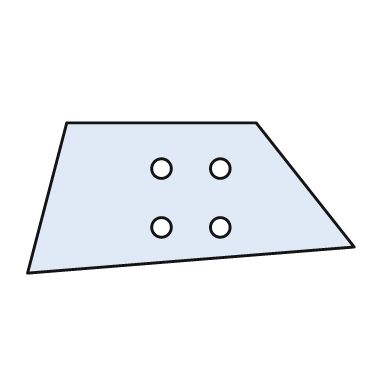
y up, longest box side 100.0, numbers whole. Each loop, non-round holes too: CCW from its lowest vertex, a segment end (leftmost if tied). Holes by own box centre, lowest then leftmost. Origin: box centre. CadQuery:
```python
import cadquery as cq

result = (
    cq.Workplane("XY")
    .moveTo(-50.0, -23.0)
    .lineTo(50.0, -15.0)
    .lineTo(20.0, 23.0)
    .lineTo(-38.0, 23.0)
    .close()
    .moveTo(-9.0, -9.0)
    .circle(3.0)
    .moveTo(9.0, -9.0)
    .circle(3.0)
    .moveTo(-9.0, 9.0)
    .circle(3.0)
    .moveTo(9.0, 9.0)
    .circle(3.0)
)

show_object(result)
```